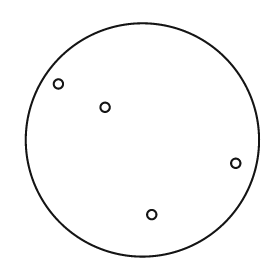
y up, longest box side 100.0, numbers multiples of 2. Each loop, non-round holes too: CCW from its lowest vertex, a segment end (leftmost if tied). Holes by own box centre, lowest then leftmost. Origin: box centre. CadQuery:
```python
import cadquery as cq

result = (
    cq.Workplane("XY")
    .moveTo(0.0, 0.0)
    .circle(50.0)
    .moveTo(4.0, -32.0)
    .circle(2.0)
    .moveTo(40.0, -10.0)
    .circle(2.0)
    .moveTo(-16.0, 14.0)
    .circle(2.0)
    .moveTo(-36.0, 24.0)
    .circle(2.0)
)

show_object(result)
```